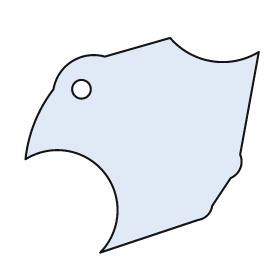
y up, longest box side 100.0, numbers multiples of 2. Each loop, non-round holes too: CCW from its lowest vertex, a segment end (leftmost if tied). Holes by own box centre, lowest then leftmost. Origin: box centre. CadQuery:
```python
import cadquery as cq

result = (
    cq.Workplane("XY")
    .moveTo(-18.0, -46.0)
    .lineTo(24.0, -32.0)
    .threePointArc((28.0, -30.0), (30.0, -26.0))
    .lineTo(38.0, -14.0)
    .threePointArc((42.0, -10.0), (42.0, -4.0))
    .lineTo(50.0, 40.0)
    .threePointArc((30.0, 36.0), (12.0, 46.0))
    .lineTo(-16.0, 38.0)
    .threePointArc((-30.0, 36.0), (-38.0, 24.0))
    .threePointArc((-46.0, 10.0), (-50.0, -6.0))
    .threePointArc((-16.0, -12.0), (-18.0, -46.0))
    .close()
    .moveTo(-26.0, 24.0)
    .circle(4.0)
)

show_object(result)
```